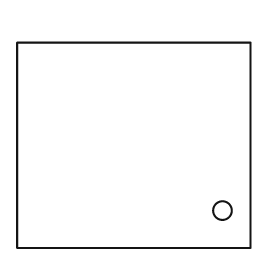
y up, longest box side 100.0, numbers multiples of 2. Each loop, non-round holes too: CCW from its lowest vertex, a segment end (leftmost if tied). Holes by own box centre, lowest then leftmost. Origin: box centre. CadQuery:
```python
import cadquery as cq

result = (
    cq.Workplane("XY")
    .moveTo(-50.0, -44.0)
    .lineTo(50.0, -44.0)
    .lineTo(50.0, 44.0)
    .lineTo(-50.0, 44.0)
    .close()
    .moveTo(38.0, -28.0)
    .circle(4.0)
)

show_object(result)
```